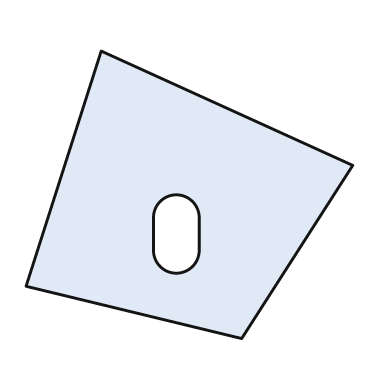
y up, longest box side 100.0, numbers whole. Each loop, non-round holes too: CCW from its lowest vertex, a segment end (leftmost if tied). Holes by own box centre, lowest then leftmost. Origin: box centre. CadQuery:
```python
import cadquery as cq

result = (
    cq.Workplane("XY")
    .moveTo(16.0, -44.0)
    .lineTo(50.0, 9.0)
    .lineTo(-27.0, 44.0)
    .lineTo(-50.0, -28.0)
    .close()
    .moveTo(-11.0, -17.0)
    .threePointArc((-4.0, -24.0), (3.0, -17.0))
    .lineTo(3.0, -7.0)
    .threePointArc((-4.0, 0.0), (-11.0, -7.0))
    .close()
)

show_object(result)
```